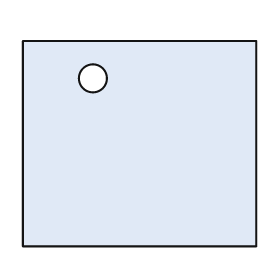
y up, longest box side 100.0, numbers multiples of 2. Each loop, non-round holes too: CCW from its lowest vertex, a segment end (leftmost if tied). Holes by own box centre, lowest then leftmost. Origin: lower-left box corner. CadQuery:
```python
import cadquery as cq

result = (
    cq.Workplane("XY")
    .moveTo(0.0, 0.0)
    .lineTo(100.0, 0.0)
    .lineTo(100.0, 88.0)
    .lineTo(0.0, 88.0)
    .close()
    .moveTo(30.0, 72.0)
    .circle(6.0)
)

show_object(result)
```